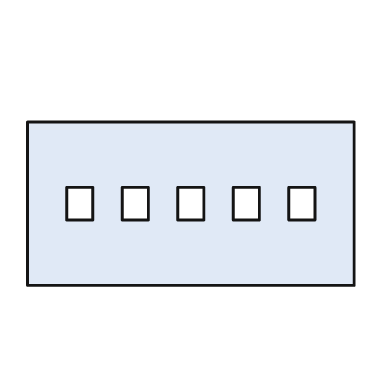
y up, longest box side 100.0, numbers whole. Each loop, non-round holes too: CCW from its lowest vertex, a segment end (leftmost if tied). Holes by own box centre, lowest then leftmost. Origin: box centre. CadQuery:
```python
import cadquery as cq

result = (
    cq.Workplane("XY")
    .moveTo(-50.0, -25.0)
    .lineTo(50.0, -25.0)
    .lineTo(50.0, 25.0)
    .lineTo(-50.0, 25.0)
    .close()
    .moveTo(-38.0, -5.0)
    .lineTo(-30.0, -5.0)
    .lineTo(-30.0, 5.0)
    .lineTo(-38.0, 5.0)
    .close()
    .moveTo(-21.0, -5.0)
    .lineTo(-13.0, -5.0)
    .lineTo(-13.0, 5.0)
    .lineTo(-21.0, 5.0)
    .close()
    .moveTo(-4.0, -5.0)
    .lineTo(4.0, -5.0)
    .lineTo(4.0, 5.0)
    .lineTo(-4.0, 5.0)
    .close()
    .moveTo(13.0, -5.0)
    .lineTo(21.0, -5.0)
    .lineTo(21.0, 5.0)
    .lineTo(13.0, 5.0)
    .close()
    .moveTo(30.0, -5.0)
    .lineTo(38.0, -5.0)
    .lineTo(38.0, 5.0)
    .lineTo(30.0, 5.0)
    .close()
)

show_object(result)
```